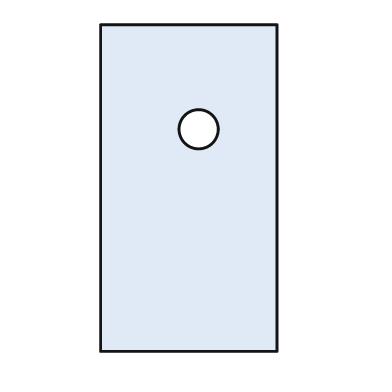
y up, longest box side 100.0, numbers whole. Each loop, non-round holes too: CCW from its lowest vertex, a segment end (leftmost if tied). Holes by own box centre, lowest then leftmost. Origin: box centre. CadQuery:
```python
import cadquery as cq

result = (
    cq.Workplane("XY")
    .moveTo(-27.0, -50.0)
    .lineTo(27.0, -50.0)
    .lineTo(27.0, 50.0)
    .lineTo(-27.0, 50.0)
    .close()
    .moveTo(3.0, 18.0)
    .circle(6.0)
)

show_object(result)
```